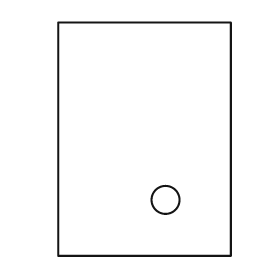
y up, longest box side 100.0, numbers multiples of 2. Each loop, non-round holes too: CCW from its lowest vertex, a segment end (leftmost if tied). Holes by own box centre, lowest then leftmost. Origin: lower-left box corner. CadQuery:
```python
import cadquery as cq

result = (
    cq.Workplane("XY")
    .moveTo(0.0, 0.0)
    .lineTo(74.0, 0.0)
    .lineTo(74.0, 100.0)
    .lineTo(0.0, 100.0)
    .close()
    .moveTo(46.0, 24.0)
    .circle(6.0)
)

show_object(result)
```